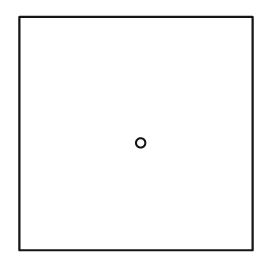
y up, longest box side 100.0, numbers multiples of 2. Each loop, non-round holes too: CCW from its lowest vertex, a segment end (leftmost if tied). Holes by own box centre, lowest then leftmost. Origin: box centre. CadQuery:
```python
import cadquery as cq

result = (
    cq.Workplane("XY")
    .moveTo(-50.0, -50.0)
    .lineTo(50.0, -50.0)
    .lineTo(50.0, 50.0)
    .lineTo(-50.0, 50.0)
    .close()
    .moveTo(2.0, -4.0)
    .circle(2.0)
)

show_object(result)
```